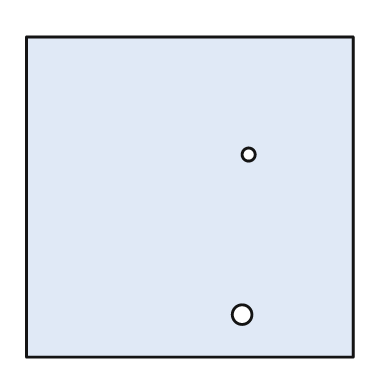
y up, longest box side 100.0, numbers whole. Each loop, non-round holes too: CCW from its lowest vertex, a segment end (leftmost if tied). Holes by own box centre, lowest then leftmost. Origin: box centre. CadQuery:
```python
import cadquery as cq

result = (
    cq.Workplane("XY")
    .moveTo(-50.0, -49.0)
    .lineTo(50.0, -49.0)
    .lineTo(50.0, 49.0)
    .lineTo(-50.0, 49.0)
    .close()
    .moveTo(16.0, -36.0)
    .circle(3.0)
    .moveTo(18.0, 13.0)
    .circle(2.0)
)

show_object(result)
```